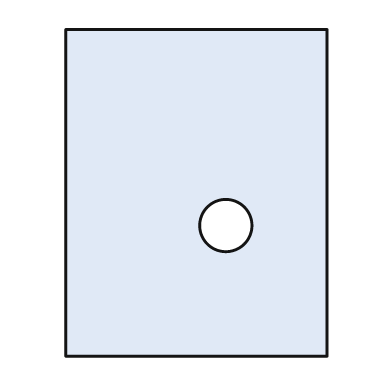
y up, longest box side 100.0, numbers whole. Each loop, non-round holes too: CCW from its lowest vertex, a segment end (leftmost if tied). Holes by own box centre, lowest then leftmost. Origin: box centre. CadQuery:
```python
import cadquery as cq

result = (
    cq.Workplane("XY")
    .moveTo(-40.0, -50.0)
    .lineTo(40.0, -50.0)
    .lineTo(40.0, 50.0)
    .lineTo(-40.0, 50.0)
    .close()
    .moveTo(9.0, -10.0)
    .circle(8.0)
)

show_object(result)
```